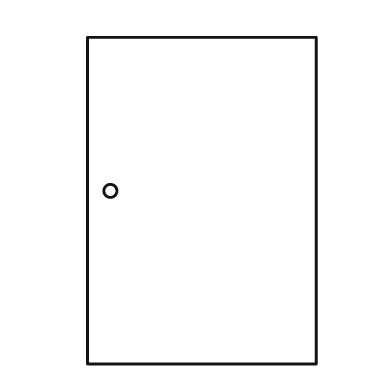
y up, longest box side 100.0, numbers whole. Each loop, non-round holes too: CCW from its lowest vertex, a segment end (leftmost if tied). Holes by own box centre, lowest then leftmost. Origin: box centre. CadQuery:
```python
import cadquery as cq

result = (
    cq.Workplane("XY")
    .moveTo(-35.0, -50.0)
    .lineTo(35.0, -50.0)
    .lineTo(35.0, 50.0)
    .lineTo(-35.0, 50.0)
    .close()
    .moveTo(-28.0, 3.0)
    .circle(2.0)
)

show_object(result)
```